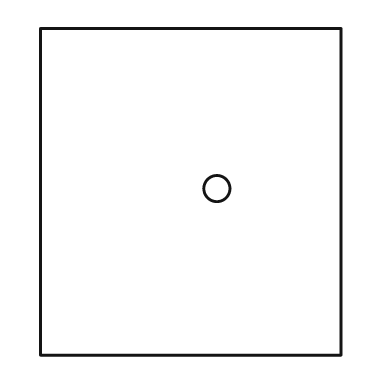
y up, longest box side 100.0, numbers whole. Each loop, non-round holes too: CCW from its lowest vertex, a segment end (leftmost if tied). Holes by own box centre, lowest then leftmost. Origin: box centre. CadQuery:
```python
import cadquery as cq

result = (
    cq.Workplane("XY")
    .moveTo(-46.0, -50.0)
    .lineTo(46.0, -50.0)
    .lineTo(46.0, 50.0)
    .lineTo(-46.0, 50.0)
    .close()
    .moveTo(8.0, 1.0)
    .circle(4.0)
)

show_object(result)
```